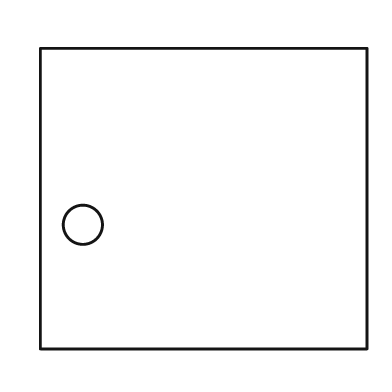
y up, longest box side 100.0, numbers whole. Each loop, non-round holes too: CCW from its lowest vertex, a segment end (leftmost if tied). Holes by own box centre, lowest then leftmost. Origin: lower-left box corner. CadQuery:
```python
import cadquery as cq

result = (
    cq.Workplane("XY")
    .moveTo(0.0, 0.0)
    .lineTo(100.0, 0.0)
    .lineTo(100.0, 92.0)
    .lineTo(0.0, 92.0)
    .close()
    .moveTo(13.0, 38.0)
    .circle(6.0)
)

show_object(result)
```